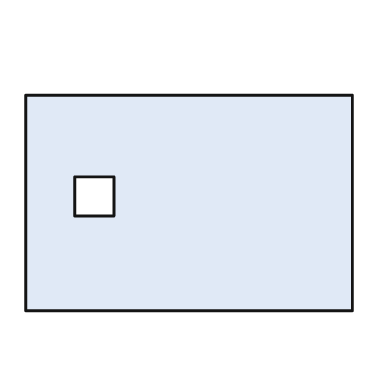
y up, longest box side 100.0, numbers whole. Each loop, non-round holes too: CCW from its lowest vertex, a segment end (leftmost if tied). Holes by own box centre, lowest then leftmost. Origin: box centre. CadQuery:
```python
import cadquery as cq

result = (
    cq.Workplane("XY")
    .moveTo(-50.0, -33.0)
    .lineTo(50.0, -33.0)
    .lineTo(50.0, 33.0)
    .lineTo(-50.0, 33.0)
    .close()
    .moveTo(-35.0, -4.0)
    .lineTo(-23.0, -4.0)
    .lineTo(-23.0, 8.0)
    .lineTo(-35.0, 8.0)
    .close()
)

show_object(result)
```